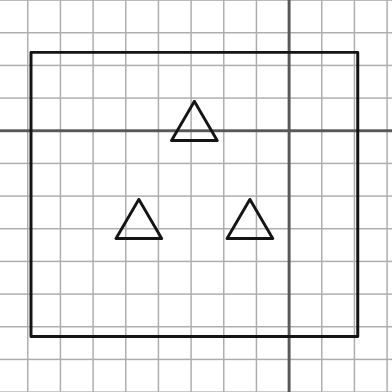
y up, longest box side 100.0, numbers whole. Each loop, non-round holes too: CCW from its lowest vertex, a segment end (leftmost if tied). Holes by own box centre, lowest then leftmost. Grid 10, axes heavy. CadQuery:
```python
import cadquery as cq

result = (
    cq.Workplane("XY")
    .moveTo(-79.0, -63.0)
    .lineTo(21.0, -63.0)
    .lineTo(21.0, 24.0)
    .lineTo(-79.0, 24.0)
    .close()
    .moveTo(-53.0, -33.0)
    .lineTo(-39.0, -33.0)
    .lineTo(-46.0, -21.0)
    .close()
    .moveTo(-19.0, -33.0)
    .lineTo(-5.0, -33.0)
    .lineTo(-12.0, -21.0)
    .close()
    .moveTo(-36.0, -3.0)
    .lineTo(-22.0, -3.0)
    .lineTo(-29.0, 9.0)
    .close()
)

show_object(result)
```